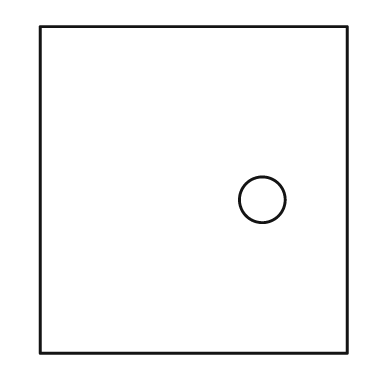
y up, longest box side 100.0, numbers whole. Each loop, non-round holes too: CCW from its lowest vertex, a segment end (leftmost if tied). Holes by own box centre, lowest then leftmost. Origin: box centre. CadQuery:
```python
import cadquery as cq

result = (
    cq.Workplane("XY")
    .moveTo(-47.0, -50.0)
    .lineTo(47.0, -50.0)
    .lineTo(47.0, 50.0)
    .lineTo(-47.0, 50.0)
    .close()
    .moveTo(21.0, -3.0)
    .circle(7.0)
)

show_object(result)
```